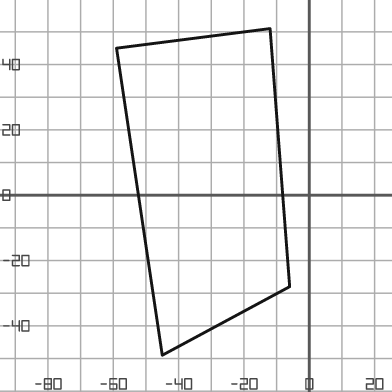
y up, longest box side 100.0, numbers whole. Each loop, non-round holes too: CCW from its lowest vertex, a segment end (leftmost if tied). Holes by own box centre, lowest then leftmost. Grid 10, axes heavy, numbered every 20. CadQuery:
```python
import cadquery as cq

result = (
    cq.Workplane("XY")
    .moveTo(-45.0, -49.0)
    .lineTo(-6.0, -28.0)
    .lineTo(-12.0, 51.0)
    .lineTo(-59.0, 45.0)
    .close()
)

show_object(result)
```